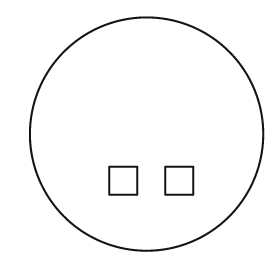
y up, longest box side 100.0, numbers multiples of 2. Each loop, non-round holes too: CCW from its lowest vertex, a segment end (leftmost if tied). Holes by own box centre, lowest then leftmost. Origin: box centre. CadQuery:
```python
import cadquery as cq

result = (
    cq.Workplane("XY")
    .moveTo(0.0, 0.0)
    .circle(50.0)
    .moveTo(-16.0, -26.0)
    .lineTo(-4.0, -26.0)
    .lineTo(-4.0, -14.0)
    .lineTo(-16.0, -14.0)
    .close()
    .moveTo(8.0, -26.0)
    .lineTo(20.0, -26.0)
    .lineTo(20.0, -14.0)
    .lineTo(8.0, -14.0)
    .close()
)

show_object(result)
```